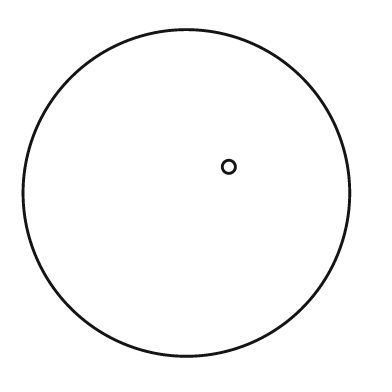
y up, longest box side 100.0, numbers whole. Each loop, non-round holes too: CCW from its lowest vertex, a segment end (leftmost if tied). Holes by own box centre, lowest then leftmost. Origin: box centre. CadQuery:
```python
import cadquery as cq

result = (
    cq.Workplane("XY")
    .moveTo(0.0, 0.0)
    .circle(50.0)
    .moveTo(13.0, 8.0)
    .circle(2.0)
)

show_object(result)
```